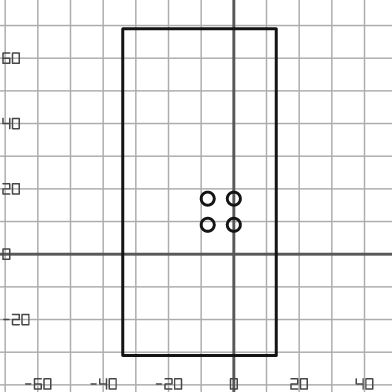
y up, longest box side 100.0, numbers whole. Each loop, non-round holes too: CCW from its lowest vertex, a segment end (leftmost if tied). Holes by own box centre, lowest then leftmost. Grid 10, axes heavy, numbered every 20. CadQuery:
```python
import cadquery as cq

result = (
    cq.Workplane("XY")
    .moveTo(-34.0, -31.0)
    .lineTo(13.0, -31.0)
    .lineTo(13.0, 69.0)
    .lineTo(-34.0, 69.0)
    .close()
    .moveTo(-8.0, 9.0)
    .circle(2.0)
    .moveTo(0.0, 9.0)
    .circle(2.0)
    .moveTo(-8.0, 17.0)
    .circle(2.0)
    .moveTo(0.0, 17.0)
    .circle(2.0)
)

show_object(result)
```